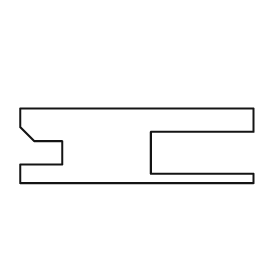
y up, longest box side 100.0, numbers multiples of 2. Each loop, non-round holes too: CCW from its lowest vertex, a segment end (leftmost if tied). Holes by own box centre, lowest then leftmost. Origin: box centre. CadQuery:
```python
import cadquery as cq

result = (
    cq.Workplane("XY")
    .moveTo(-50.0, -16.0)
    .lineTo(50.0, -16.0)
    .lineTo(50.0, -12.0)
    .lineTo(6.0, -12.0)
    .lineTo(6.0, 6.0)
    .lineTo(50.0, 6.0)
    .lineTo(50.0, 16.0)
    .lineTo(-50.0, 16.0)
    .lineTo(-50.0, 8.0)
    .lineTo(-44.0, 2.0)
    .lineTo(-32.0, 2.0)
    .lineTo(-32.0, -8.0)
    .lineTo(-50.0, -8.0)
    .close()
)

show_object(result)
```